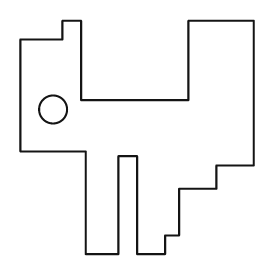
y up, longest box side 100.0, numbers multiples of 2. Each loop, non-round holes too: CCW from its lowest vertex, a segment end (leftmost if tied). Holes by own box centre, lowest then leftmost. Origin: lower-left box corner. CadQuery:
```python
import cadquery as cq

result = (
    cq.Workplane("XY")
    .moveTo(28.0, 0.0)
    .lineTo(42.0, 0.0)
    .lineTo(42.0, 42.0)
    .lineTo(50.0, 42.0)
    .lineTo(50.0, 0.0)
    .lineTo(62.0, 0.0)
    .lineTo(62.0, 8.0)
    .lineTo(68.0, 8.0)
    .lineTo(68.0, 28.0)
    .lineTo(84.0, 28.0)
    .lineTo(84.0, 38.0)
    .lineTo(100.0, 38.0)
    .lineTo(100.0, 100.0)
    .lineTo(72.0, 100.0)
    .lineTo(72.0, 66.0)
    .lineTo(26.0, 66.0)
    .lineTo(26.0, 100.0)
    .lineTo(18.0, 100.0)
    .lineTo(18.0, 92.0)
    .lineTo(0.0, 92.0)
    .lineTo(0.0, 44.0)
    .lineTo(28.0, 44.0)
    .close()
    .moveTo(14.0, 62.0)
    .circle(6.0)
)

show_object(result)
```